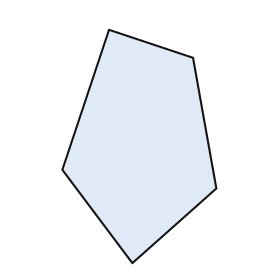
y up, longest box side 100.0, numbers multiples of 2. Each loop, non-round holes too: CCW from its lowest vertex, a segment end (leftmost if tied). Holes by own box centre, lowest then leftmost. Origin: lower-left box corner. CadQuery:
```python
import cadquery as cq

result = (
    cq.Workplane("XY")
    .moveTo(30.0, 0.0)
    .lineTo(66.0, 32.0)
    .lineTo(56.0, 88.0)
    .lineTo(20.0, 100.0)
    .lineTo(0.0, 40.0)
    .close()
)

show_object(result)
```